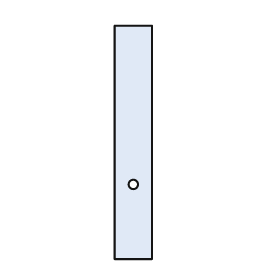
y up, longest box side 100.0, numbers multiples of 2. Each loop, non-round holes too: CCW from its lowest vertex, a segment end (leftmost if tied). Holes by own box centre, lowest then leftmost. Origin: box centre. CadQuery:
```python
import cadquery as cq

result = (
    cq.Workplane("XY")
    .moveTo(-8.0, -50.0)
    .lineTo(8.0, -50.0)
    .lineTo(8.0, 50.0)
    .lineTo(-8.0, 50.0)
    .close()
    .moveTo(0.0, -18.0)
    .circle(2.0)
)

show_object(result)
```